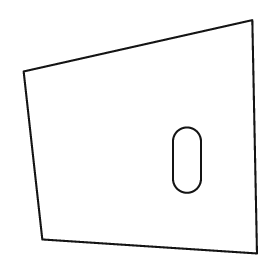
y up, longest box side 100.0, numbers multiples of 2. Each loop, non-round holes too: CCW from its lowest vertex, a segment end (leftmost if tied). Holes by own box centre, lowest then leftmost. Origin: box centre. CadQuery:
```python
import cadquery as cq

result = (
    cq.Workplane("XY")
    .moveTo(50.0, -50.0)
    .lineTo(48.0, 50.0)
    .lineTo(-50.0, 28.0)
    .lineTo(-42.0, -44.0)
    .close()
    .moveTo(14.0, -18.0)
    .threePointArc((20.0, -24.0), (26.0, -18.0))
    .lineTo(26.0, -2.0)
    .threePointArc((20.0, 4.0), (14.0, -2.0))
    .close()
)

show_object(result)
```